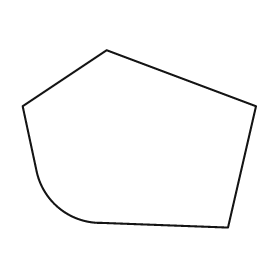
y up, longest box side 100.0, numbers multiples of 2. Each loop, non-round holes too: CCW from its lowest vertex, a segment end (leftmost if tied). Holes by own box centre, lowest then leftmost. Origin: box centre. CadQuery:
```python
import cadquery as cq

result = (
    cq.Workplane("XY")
    .moveTo(38.0, -38.0)
    .lineTo(50.0, 14.0)
    .lineTo(-14.0, 38.0)
    .lineTo(-50.0, 14.0)
    .lineTo(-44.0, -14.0)
    .threePointArc((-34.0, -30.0), (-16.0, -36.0))
    .close()
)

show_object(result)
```